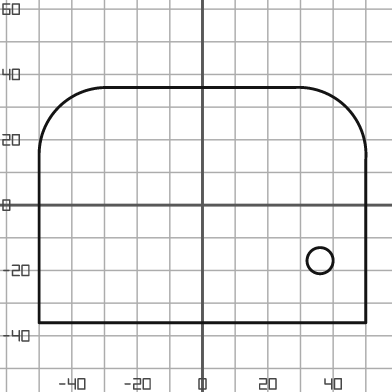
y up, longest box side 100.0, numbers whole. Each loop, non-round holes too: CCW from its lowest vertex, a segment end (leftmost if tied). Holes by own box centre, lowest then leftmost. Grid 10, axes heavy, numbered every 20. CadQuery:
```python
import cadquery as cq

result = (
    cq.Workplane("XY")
    .moveTo(-50.0, -36.0)
    .lineTo(50.0, -36.0)
    .lineTo(50.0, 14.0)
    .threePointArc((44.0, 30.0), (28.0, 36.0))
    .lineTo(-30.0, 36.0)
    .threePointArc((-44.0, 30.0), (-50.0, 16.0))
    .close()
    .moveTo(36.0, -17.0)
    .circle(4.0)
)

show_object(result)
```